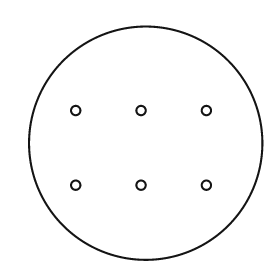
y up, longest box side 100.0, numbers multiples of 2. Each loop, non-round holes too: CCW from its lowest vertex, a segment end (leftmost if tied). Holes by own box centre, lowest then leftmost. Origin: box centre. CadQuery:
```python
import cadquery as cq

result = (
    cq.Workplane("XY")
    .moveTo(0.0, 0.0)
    .circle(50.0)
    .moveTo(-30.0, -18.0)
    .circle(2.0)
    .moveTo(-2.0, -18.0)
    .circle(2.0)
    .moveTo(26.0, -18.0)
    .circle(2.0)
    .moveTo(-30.0, 14.0)
    .circle(2.0)
    .moveTo(-2.0, 14.0)
    .circle(2.0)
    .moveTo(26.0, 14.0)
    .circle(2.0)
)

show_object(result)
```